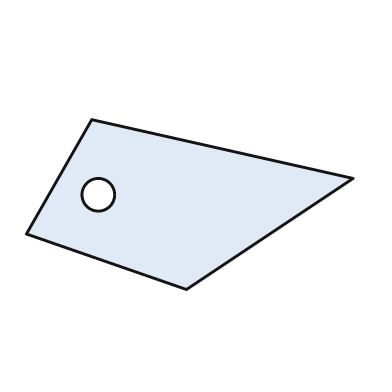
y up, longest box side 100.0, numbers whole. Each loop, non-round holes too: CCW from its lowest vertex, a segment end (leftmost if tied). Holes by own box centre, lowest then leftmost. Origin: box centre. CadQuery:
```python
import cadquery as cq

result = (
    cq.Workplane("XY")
    .moveTo(-1.0, -26.0)
    .lineTo(50.0, 8.0)
    .lineTo(-30.0, 26.0)
    .lineTo(-50.0, -9.0)
    .close()
    .moveTo(-28.0, 3.0)
    .circle(5.0)
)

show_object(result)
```